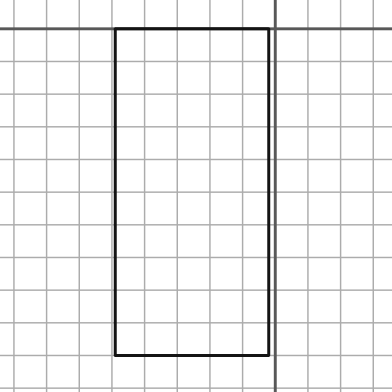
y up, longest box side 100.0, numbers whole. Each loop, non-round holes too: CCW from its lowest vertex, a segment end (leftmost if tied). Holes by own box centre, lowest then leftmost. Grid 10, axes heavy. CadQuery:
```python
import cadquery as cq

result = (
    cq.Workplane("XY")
    .moveTo(-49.0, -100.0)
    .lineTo(-2.0, -100.0)
    .lineTo(-2.0, 0.0)
    .lineTo(-49.0, 0.0)
    .close()
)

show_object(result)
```